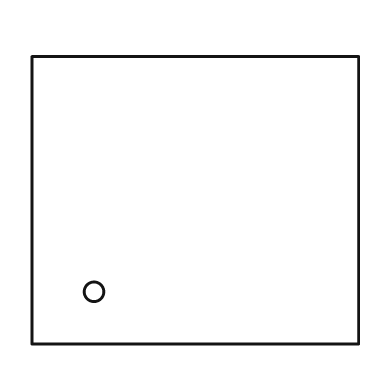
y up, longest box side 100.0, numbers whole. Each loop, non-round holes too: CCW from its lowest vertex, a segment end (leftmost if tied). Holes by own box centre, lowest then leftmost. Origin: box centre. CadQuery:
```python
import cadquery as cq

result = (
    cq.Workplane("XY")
    .moveTo(-50.0, -44.0)
    .lineTo(50.0, -44.0)
    .lineTo(50.0, 44.0)
    .lineTo(-50.0, 44.0)
    .close()
    .moveTo(-31.0, -28.0)
    .circle(3.0)
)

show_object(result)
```